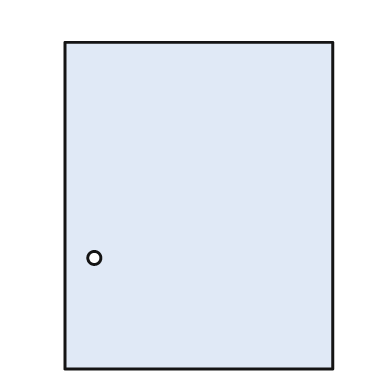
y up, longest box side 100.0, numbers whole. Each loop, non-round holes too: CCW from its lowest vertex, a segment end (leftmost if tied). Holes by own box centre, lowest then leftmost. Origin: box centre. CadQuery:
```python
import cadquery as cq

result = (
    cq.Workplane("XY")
    .moveTo(-41.0, -50.0)
    .lineTo(41.0, -50.0)
    .lineTo(41.0, 50.0)
    .lineTo(-41.0, 50.0)
    .close()
    .moveTo(-32.0, -16.0)
    .circle(2.0)
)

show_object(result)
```